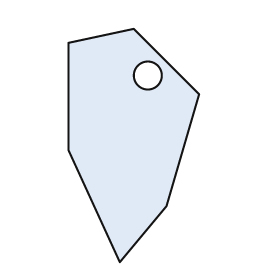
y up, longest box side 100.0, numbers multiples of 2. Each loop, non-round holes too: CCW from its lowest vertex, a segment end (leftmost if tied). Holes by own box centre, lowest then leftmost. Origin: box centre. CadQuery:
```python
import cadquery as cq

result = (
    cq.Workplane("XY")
    .moveTo(-6.0, -50.0)
    .lineTo(14.0, -26.0)
    .lineTo(28.0, 22.0)
    .lineTo(0.0, 50.0)
    .lineTo(-28.0, 44.0)
    .lineTo(-28.0, -2.0)
    .close()
    .moveTo(6.0, 30.0)
    .circle(6.0)
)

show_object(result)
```